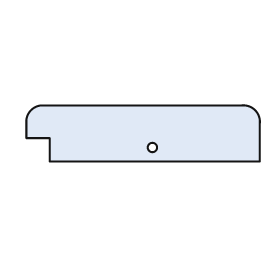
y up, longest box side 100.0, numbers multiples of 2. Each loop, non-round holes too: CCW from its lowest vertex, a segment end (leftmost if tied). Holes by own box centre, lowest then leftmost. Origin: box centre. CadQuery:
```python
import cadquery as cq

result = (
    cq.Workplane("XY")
    .moveTo(-40.0, -12.0)
    .lineTo(50.0, -12.0)
    .lineTo(50.0, 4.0)
    .threePointArc((48.0, 10.0), (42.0, 12.0))
    .lineTo(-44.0, 12.0)
    .threePointArc((-48.0, 10.0), (-50.0, 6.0))
    .lineTo(-50.0, -2.0)
    .lineTo(-40.0, -2.0)
    .close()
    .moveTo(4.0, -6.0)
    .circle(2.0)
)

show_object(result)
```